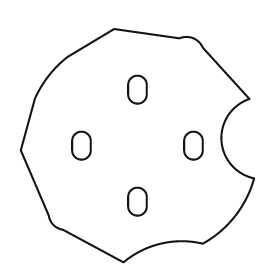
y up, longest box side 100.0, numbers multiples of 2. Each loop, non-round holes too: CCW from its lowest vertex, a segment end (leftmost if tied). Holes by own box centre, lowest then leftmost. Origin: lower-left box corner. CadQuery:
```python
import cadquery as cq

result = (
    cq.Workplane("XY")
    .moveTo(44.0, 0.0)
    .threePointArc((60.0, 8.0), (78.0, 8.0))
    .threePointArc((92.0, 20.0), (100.0, 36.0))
    .threePointArc((86.0, 52.0), (98.0, 70.0))
    .lineTo(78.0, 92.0)
    .threePointArc((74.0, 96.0), (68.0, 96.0))
    .lineTo(40.0, 100.0)
    .lineTo(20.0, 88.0)
    .threePointArc((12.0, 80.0), (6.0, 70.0))
    .lineTo(0.0, 48.0)
    .lineTo(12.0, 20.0)
    .threePointArc((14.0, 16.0), (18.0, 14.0))
    .close()
    .moveTo(46.0, 24.0)
    .threePointArc((50.0, 20.0), (54.0, 24.0))
    .lineTo(54.0, 28.0)
    .threePointArc((50.0, 32.0), (46.0, 28.0))
    .close()
    .moveTo(22.0, 48.0)
    .threePointArc((26.0, 44.0), (30.0, 48.0))
    .lineTo(30.0, 52.0)
    .threePointArc((26.0, 56.0), (22.0, 52.0))
    .close()
    .moveTo(70.0, 48.0)
    .threePointArc((74.0, 44.0), (78.0, 48.0))
    .lineTo(78.0, 52.0)
    .threePointArc((74.0, 56.0), (70.0, 52.0))
    .close()
    .moveTo(46.0, 72.0)
    .threePointArc((50.0, 68.0), (54.0, 72.0))
    .lineTo(54.0, 76.0)
    .threePointArc((50.0, 80.0), (46.0, 76.0))
    .close()
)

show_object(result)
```